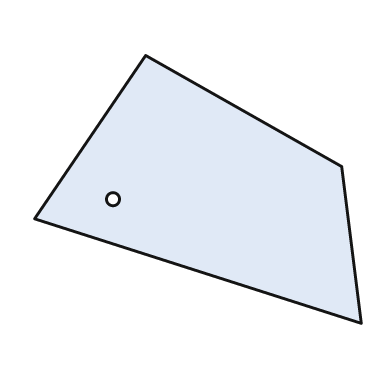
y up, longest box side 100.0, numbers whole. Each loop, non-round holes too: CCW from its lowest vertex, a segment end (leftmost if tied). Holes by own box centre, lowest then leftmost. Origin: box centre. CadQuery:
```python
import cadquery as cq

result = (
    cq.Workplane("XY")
    .moveTo(50.0, -41.0)
    .lineTo(44.0, 7.0)
    .lineTo(-16.0, 41.0)
    .lineTo(-50.0, -9.0)
    .close()
    .moveTo(-26.0, -3.0)
    .circle(2.0)
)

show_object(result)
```